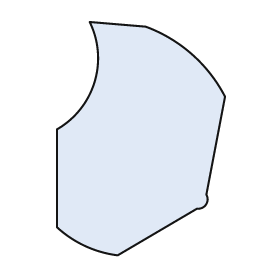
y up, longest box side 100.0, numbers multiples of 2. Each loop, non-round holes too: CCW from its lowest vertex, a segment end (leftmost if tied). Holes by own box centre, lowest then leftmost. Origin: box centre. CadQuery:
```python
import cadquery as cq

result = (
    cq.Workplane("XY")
    .moveTo(-10.0, -50.0)
    .lineTo(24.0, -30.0)
    .threePointArc((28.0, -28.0), (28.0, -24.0))
    .lineTo(36.0, 18.0)
    .threePointArc((22.0, 36.0), (2.0, 48.0))
    .lineTo(-22.0, 50.0)
    .threePointArc((-20.0, 24.0), (-36.0, 4.0))
    .lineTo(-36.0, -38.0)
    .threePointArc((-24.0, -46.0), (-10.0, -50.0))
    .close()
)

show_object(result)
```